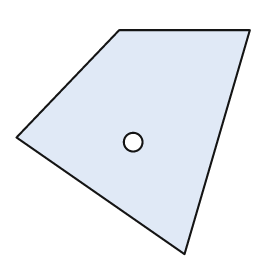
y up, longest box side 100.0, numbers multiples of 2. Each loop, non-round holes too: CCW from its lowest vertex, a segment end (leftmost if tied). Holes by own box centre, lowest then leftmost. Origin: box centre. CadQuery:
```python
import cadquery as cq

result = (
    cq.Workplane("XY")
    .moveTo(22.0, -48.0)
    .lineTo(50.0, 48.0)
    .lineTo(-6.0, 48.0)
    .lineTo(-50.0, 2.0)
    .close()
    .moveTo(0.0, 0.0)
    .circle(4.0)
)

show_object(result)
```